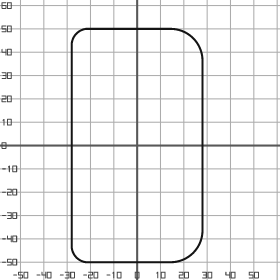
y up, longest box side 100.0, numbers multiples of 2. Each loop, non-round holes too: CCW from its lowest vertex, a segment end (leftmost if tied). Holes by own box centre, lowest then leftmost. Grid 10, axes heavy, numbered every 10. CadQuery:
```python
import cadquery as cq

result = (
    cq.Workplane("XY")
    .moveTo(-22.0, -50.0)
    .lineTo(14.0, -50.0)
    .threePointArc((24.0, -46.0), (28.0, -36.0))
    .lineTo(28.0, 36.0)
    .threePointArc((24.0, 46.0), (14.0, 50.0))
    .lineTo(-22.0, 50.0)
    .threePointArc((-26.0, 48.0), (-28.0, 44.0))
    .lineTo(-28.0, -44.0)
    .threePointArc((-26.0, -48.0), (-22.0, -50.0))
    .close()
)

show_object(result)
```